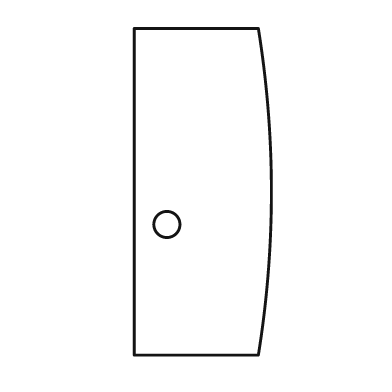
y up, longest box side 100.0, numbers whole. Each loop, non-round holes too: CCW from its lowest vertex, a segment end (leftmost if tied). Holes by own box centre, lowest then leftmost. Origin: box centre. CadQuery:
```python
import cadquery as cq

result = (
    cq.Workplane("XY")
    .moveTo(-21.0, -50.0)
    .lineTo(17.0, -50.0)
    .threePointArc((21.0, 0.0), (17.0, 50.0))
    .lineTo(-21.0, 50.0)
    .close()
    .moveTo(-11.0, -10.0)
    .circle(4.0)
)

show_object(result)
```